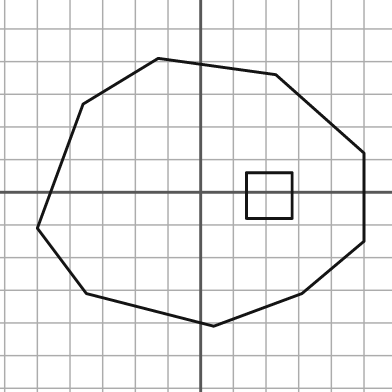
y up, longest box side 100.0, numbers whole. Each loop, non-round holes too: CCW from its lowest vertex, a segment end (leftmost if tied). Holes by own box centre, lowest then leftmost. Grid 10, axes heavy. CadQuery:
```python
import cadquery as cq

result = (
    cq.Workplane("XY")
    .moveTo(4.0, -41.0)
    .lineTo(31.0, -31.0)
    .lineTo(50.0, -15.0)
    .lineTo(50.0, 12.0)
    .lineTo(23.0, 36.0)
    .lineTo(-13.0, 41.0)
    .lineTo(-36.0, 27.0)
    .lineTo(-50.0, -11.0)
    .lineTo(-35.0, -31.0)
    .close()
    .moveTo(14.0, -8.0)
    .lineTo(28.0, -8.0)
    .lineTo(28.0, 6.0)
    .lineTo(14.0, 6.0)
    .close()
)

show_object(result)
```